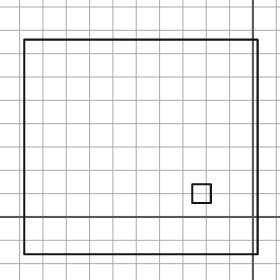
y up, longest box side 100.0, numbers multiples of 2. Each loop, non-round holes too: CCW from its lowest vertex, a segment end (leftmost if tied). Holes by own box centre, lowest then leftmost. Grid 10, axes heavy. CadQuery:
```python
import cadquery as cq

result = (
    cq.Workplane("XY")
    .moveTo(-98.0, -16.0)
    .lineTo(2.0, -16.0)
    .lineTo(2.0, 76.0)
    .lineTo(-98.0, 76.0)
    .close()
    .moveTo(-26.0, 6.0)
    .lineTo(-18.0, 6.0)
    .lineTo(-18.0, 14.0)
    .lineTo(-26.0, 14.0)
    .close()
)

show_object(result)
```